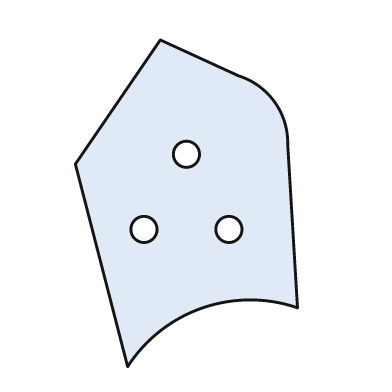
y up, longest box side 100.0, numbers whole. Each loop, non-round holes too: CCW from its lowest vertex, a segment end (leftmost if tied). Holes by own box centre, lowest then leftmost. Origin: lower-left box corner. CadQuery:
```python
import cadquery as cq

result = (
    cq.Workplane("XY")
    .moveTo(16.0, 0.0)
    .threePointArc((39.0, 18.0), (68.0, 18.0))
    .lineTo(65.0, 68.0)
    .threePointArc((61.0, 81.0), (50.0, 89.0))
    .lineTo(26.0, 100.0)
    .lineTo(0.0, 62.0)
    .close()
    .moveTo(21.0, 42.0)
    .circle(4.0)
    .moveTo(47.0, 42.0)
    .circle(4.0)
    .moveTo(34.0, 65.0)
    .circle(4.0)
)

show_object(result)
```